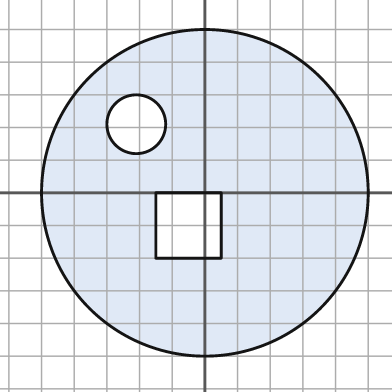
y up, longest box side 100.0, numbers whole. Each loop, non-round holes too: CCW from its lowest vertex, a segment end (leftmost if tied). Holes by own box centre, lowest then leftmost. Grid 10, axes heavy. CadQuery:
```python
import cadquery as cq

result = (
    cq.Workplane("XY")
    .moveTo(0.0, 0.0)
    .circle(50.0)
    .moveTo(-15.0, -20.0)
    .lineTo(5.0, -20.0)
    .lineTo(5.0, 0.0)
    .lineTo(-15.0, 0.0)
    .close()
    .moveTo(-21.0, 21.0)
    .circle(9.0)
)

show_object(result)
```